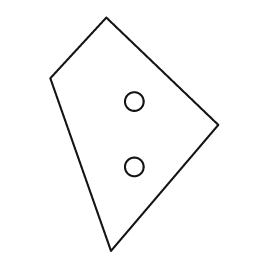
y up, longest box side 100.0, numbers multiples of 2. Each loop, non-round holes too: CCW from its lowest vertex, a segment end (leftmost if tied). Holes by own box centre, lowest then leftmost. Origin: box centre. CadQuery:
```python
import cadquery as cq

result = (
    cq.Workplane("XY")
    .moveTo(-10.0, -50.0)
    .lineTo(36.0, 4.0)
    .lineTo(-12.0, 50.0)
    .lineTo(-36.0, 24.0)
    .close()
    .moveTo(0.0, -14.0)
    .circle(4.0)
    .moveTo(0.0, 14.0)
    .circle(4.0)
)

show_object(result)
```